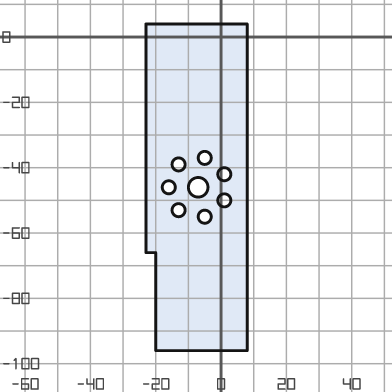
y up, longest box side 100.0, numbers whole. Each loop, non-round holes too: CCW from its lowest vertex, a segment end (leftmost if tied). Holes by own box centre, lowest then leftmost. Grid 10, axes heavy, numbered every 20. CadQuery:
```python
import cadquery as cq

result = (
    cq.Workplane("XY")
    .moveTo(-20.0, -96.0)
    .lineTo(8.0, -96.0)
    .lineTo(8.0, 4.0)
    .lineTo(-23.0, 4.0)
    .lineTo(-23.0, -66.0)
    .lineTo(-20.0, -66.0)
    .close()
    .moveTo(-5.0, -55.0)
    .circle(2.0)
    .moveTo(-13.0, -53.0)
    .circle(2.0)
    .moveTo(1.0, -50.0)
    .circle(2.0)
    .moveTo(-16.0, -46.0)
    .circle(2.0)
    .moveTo(-7.0, -46.0)
    .circle(3.0)
    .moveTo(1.0, -42.0)
    .circle(2.0)
    .moveTo(-13.0, -39.0)
    .circle(2.0)
    .moveTo(-5.0, -37.0)
    .circle(2.0)
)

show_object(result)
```